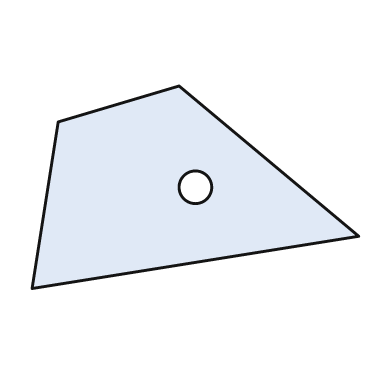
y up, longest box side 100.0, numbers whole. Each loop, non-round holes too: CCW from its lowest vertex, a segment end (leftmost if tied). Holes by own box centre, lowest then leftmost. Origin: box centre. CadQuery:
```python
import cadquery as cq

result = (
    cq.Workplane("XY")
    .moveTo(-50.0, -31.0)
    .lineTo(50.0, -15.0)
    .lineTo(-5.0, 31.0)
    .lineTo(-42.0, 20.0)
    .close()
    .moveTo(0.0, 0.0)
    .circle(5.0)
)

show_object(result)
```